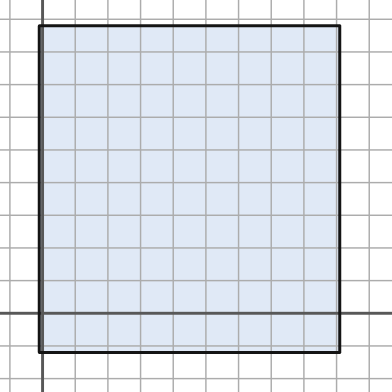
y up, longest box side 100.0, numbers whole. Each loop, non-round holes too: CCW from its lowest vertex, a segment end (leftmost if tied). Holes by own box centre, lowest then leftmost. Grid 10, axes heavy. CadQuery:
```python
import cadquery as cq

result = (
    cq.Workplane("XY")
    .moveTo(-1.0, -12.0)
    .lineTo(91.0, -12.0)
    .lineTo(91.0, 88.0)
    .lineTo(-1.0, 88.0)
    .close()
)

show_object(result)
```